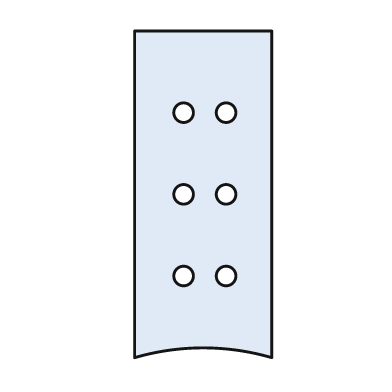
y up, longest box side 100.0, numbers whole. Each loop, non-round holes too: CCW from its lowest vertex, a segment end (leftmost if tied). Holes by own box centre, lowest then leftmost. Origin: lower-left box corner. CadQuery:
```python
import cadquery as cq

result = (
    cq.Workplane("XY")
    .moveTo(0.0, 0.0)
    .threePointArc((21.0, 3.0), (42.0, 0.0))
    .lineTo(42.0, 100.0)
    .lineTo(0.0, 100.0)
    .close()
    .moveTo(15.0, 25.0)
    .circle(3.0)
    .moveTo(28.0, 25.0)
    .circle(3.0)
    .moveTo(15.0, 50.0)
    .circle(3.0)
    .moveTo(28.0, 50.0)
    .circle(3.0)
    .moveTo(15.0, 75.0)
    .circle(3.0)
    .moveTo(28.0, 75.0)
    .circle(3.0)
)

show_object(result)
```